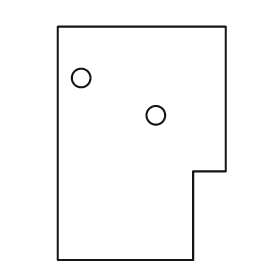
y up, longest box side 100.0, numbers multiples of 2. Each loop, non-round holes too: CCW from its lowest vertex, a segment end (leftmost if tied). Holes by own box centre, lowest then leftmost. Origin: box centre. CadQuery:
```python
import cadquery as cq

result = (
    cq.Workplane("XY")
    .moveTo(-36.0, -50.0)
    .lineTo(22.0, -50.0)
    .lineTo(22.0, -12.0)
    .lineTo(36.0, -12.0)
    .lineTo(36.0, 50.0)
    .lineTo(-36.0, 50.0)
    .close()
    .moveTo(6.0, 12.0)
    .circle(4.0)
    .moveTo(-26.0, 28.0)
    .circle(4.0)
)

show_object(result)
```